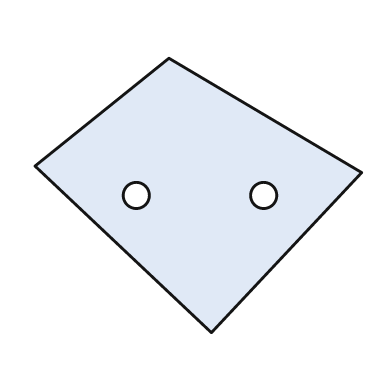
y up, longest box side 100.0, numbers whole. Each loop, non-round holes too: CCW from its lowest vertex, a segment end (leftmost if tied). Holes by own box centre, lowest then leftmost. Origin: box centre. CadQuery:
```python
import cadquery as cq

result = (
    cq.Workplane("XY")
    .moveTo(4.0, -42.0)
    .lineTo(50.0, 7.0)
    .lineTo(-9.0, 42.0)
    .lineTo(-50.0, 9.0)
    .close()
    .moveTo(-19.0, 0.0)
    .circle(4.0)
    .moveTo(20.0, 0.0)
    .circle(4.0)
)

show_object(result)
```